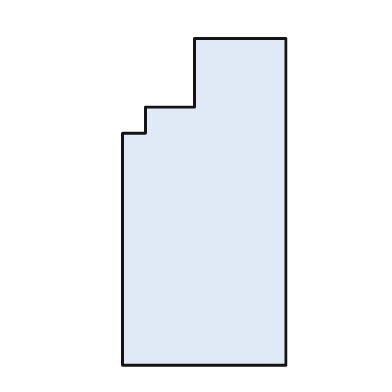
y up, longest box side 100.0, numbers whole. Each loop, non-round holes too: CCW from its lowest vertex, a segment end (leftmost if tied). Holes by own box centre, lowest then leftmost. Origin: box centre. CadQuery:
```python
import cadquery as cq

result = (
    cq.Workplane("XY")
    .moveTo(-25.0, -50.0)
    .lineTo(25.0, -50.0)
    .lineTo(25.0, 50.0)
    .lineTo(-3.0, 50.0)
    .lineTo(-3.0, 29.0)
    .lineTo(-18.0, 29.0)
    .lineTo(-18.0, 21.0)
    .lineTo(-25.0, 21.0)
    .close()
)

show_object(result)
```